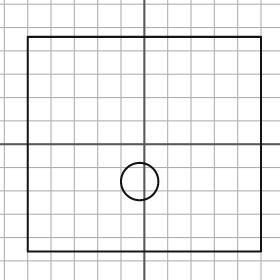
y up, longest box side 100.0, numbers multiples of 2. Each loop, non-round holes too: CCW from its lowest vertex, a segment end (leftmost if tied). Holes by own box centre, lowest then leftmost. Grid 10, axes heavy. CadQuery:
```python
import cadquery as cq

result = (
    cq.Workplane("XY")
    .moveTo(-50.0, -46.0)
    .lineTo(50.0, -46.0)
    .lineTo(50.0, 46.0)
    .lineTo(-50.0, 46.0)
    .close()
    .moveTo(-2.0, -16.0)
    .circle(8.0)
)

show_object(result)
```